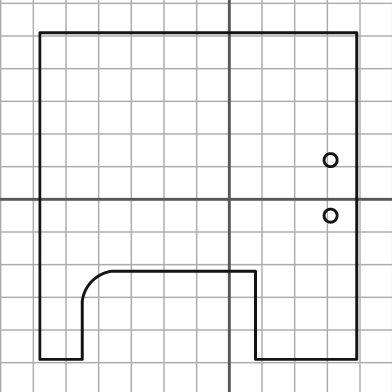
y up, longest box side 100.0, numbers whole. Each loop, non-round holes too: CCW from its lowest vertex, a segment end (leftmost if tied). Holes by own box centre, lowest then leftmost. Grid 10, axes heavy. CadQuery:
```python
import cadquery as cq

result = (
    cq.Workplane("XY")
    .moveTo(-58.0, -49.0)
    .lineTo(-45.0, -49.0)
    .lineTo(-45.0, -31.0)
    .threePointArc((-42.0, -25.0), (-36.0, -22.0))
    .lineTo(8.0, -22.0)
    .lineTo(8.0, -49.0)
    .lineTo(39.0, -49.0)
    .lineTo(39.0, 51.0)
    .lineTo(-58.0, 51.0)
    .close()
    .moveTo(31.0, -5.0)
    .circle(2.0)
    .moveTo(31.0, 12.0)
    .circle(2.0)
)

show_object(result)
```